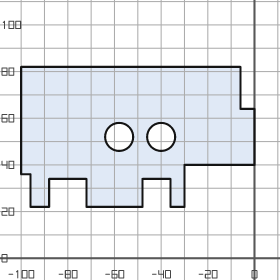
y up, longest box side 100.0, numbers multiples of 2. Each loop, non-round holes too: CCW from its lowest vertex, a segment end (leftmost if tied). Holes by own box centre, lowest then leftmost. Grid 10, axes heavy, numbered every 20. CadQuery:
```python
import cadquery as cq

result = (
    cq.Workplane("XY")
    .moveTo(-96.0, 22.0)
    .lineTo(-88.0, 22.0)
    .lineTo(-88.0, 34.0)
    .lineTo(-72.0, 34.0)
    .lineTo(-72.0, 22.0)
    .lineTo(-48.0, 22.0)
    .lineTo(-48.0, 34.0)
    .lineTo(-36.0, 34.0)
    .lineTo(-36.0, 22.0)
    .lineTo(-30.0, 22.0)
    .lineTo(-30.0, 40.0)
    .lineTo(0.0, 40.0)
    .lineTo(0.0, 64.0)
    .lineTo(-6.0, 64.0)
    .lineTo(-6.0, 82.0)
    .lineTo(-100.0, 82.0)
    .lineTo(-100.0, 36.0)
    .lineTo(-96.0, 36.0)
    .close()
    .moveTo(-58.0, 52.0)
    .circle(6.0)
    .moveTo(-40.0, 52.0)
    .circle(6.0)
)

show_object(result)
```